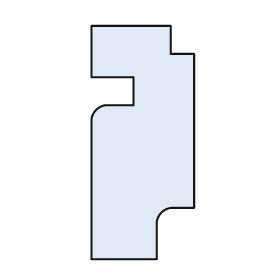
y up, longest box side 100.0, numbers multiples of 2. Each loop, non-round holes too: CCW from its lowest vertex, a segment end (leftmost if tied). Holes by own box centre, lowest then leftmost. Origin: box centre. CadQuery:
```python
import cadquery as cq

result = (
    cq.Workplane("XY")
    .moveTo(-22.0, -50.0)
    .lineTo(6.0, -50.0)
    .lineTo(6.0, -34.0)
    .threePointArc((8.0, -30.0), (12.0, -28.0))
    .lineTo(22.0, -28.0)
    .lineTo(22.0, 38.0)
    .lineTo(12.0, 38.0)
    .lineTo(12.0, 50.0)
    .lineTo(-22.0, 50.0)
    .lineTo(-22.0, 28.0)
    .lineTo(-4.0, 28.0)
    .lineTo(-4.0, 16.0)
    .lineTo(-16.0, 16.0)
    .threePointArc((-20.0, 14.0), (-22.0, 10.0))
    .close()
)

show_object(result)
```